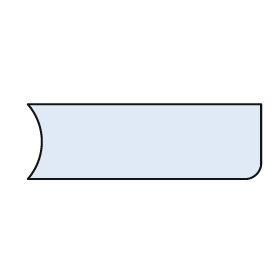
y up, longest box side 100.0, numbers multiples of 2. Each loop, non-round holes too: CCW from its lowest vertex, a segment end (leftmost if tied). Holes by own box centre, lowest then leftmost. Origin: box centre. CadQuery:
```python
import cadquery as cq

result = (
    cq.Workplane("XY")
    .moveTo(-50.0, -16.0)
    .lineTo(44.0, -16.0)
    .threePointArc((48.0, -14.0), (50.0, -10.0))
    .lineTo(50.0, 16.0)
    .lineTo(-50.0, 16.0)
    .threePointArc((-44.0, 0.0), (-50.0, -16.0))
    .close()
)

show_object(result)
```